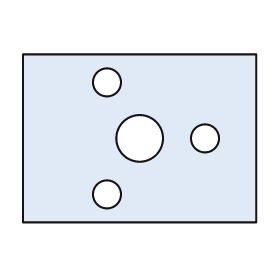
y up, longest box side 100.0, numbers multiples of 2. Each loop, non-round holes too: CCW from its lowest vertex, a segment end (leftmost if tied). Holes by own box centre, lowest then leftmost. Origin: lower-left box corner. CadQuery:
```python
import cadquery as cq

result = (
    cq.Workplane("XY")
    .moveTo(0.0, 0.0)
    .lineTo(100.0, 0.0)
    .lineTo(100.0, 72.0)
    .lineTo(0.0, 72.0)
    .close()
    .moveTo(36.0, 12.0)
    .circle(6.0)
    .moveTo(50.0, 36.0)
    .circle(10.0)
    .moveTo(78.0, 36.0)
    .circle(6.0)
    .moveTo(36.0, 60.0)
    .circle(6.0)
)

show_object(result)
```